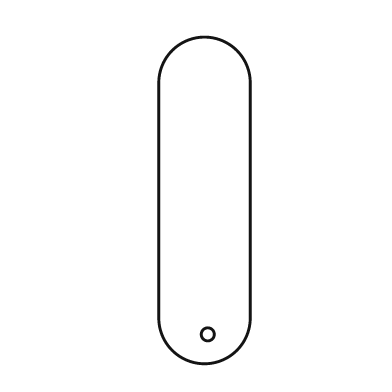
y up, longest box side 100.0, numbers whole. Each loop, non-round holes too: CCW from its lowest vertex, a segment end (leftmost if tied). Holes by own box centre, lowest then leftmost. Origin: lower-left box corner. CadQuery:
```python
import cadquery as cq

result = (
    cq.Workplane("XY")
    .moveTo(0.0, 14.0)
    .threePointArc((14.0, 0.0), (28.0, 14.0))
    .lineTo(28.0, 86.0)
    .threePointArc((14.0, 100.0), (0.0, 86.0))
    .close()
    .moveTo(15.0, 9.0)
    .circle(2.0)
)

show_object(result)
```